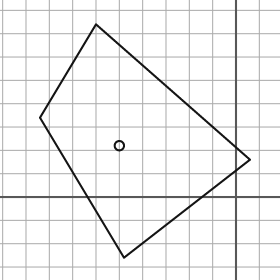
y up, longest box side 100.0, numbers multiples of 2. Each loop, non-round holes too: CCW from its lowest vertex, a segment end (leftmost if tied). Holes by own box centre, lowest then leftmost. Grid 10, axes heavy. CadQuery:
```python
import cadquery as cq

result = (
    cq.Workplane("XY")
    .moveTo(-48.0, -26.0)
    .lineTo(6.0, 16.0)
    .lineTo(-60.0, 74.0)
    .lineTo(-84.0, 34.0)
    .close()
    .moveTo(-50.0, 22.0)
    .circle(2.0)
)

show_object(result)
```